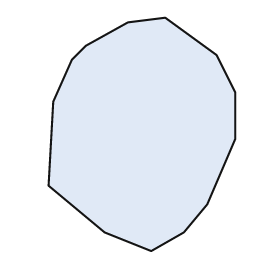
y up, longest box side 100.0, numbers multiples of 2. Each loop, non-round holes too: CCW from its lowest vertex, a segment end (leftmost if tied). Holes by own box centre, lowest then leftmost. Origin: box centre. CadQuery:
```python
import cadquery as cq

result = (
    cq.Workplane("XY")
    .moveTo(4.0, -50.0)
    .lineTo(18.0, -42.0)
    .lineTo(28.0, -30.0)
    .lineTo(40.0, -2.0)
    .lineTo(40.0, 18.0)
    .lineTo(32.0, 34.0)
    .lineTo(10.0, 50.0)
    .lineTo(-6.0, 48.0)
    .lineTo(-24.0, 38.0)
    .lineTo(-30.0, 32.0)
    .lineTo(-38.0, 14.0)
    .lineTo(-40.0, -22.0)
    .lineTo(-16.0, -42.0)
    .close()
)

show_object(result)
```